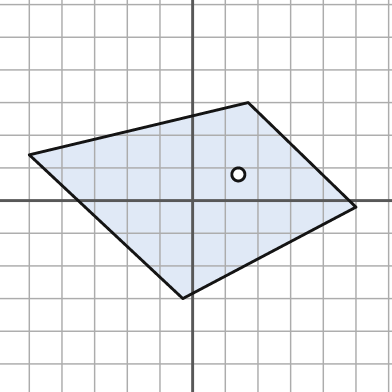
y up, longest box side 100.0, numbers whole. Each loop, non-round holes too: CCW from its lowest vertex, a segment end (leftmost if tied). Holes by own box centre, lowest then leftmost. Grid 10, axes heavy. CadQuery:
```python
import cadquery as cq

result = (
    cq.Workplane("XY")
    .moveTo(-3.0, -30.0)
    .lineTo(50.0, -2.0)
    .lineTo(17.0, 30.0)
    .lineTo(-50.0, 14.0)
    .close()
    .moveTo(14.0, 8.0)
    .circle(2.0)
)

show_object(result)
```